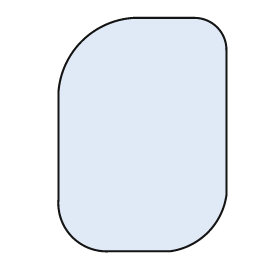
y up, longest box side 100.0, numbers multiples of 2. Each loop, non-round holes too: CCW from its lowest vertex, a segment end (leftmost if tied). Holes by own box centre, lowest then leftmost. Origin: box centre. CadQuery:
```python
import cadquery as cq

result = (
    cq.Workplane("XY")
    .moveTo(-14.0, -50.0)
    .lineTo(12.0, -50.0)
    .threePointArc((28.0, -42.0), (36.0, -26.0))
    .lineTo(36.0, 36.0)
    .threePointArc((32.0, 46.0), (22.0, 50.0))
    .lineTo(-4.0, 50.0)
    .threePointArc((-26.0, 40.0), (-36.0, 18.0))
    .lineTo(-36.0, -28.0)
    .threePointArc((-30.0, -44.0), (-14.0, -50.0))
    .close()
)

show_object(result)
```